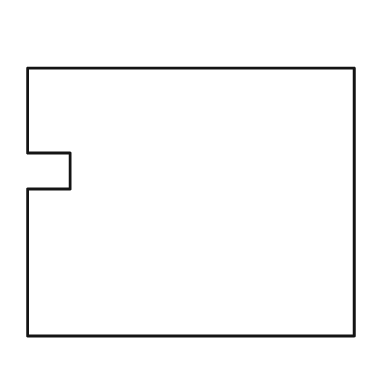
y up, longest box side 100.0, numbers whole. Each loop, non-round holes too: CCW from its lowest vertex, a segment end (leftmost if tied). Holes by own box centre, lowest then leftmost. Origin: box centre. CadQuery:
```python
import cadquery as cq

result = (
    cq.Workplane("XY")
    .moveTo(-50.0, -41.0)
    .lineTo(50.0, -41.0)
    .lineTo(50.0, 41.0)
    .lineTo(-50.0, 41.0)
    .lineTo(-50.0, 15.0)
    .lineTo(-37.0, 15.0)
    .lineTo(-37.0, 4.0)
    .lineTo(-50.0, 4.0)
    .close()
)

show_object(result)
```